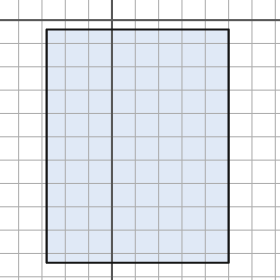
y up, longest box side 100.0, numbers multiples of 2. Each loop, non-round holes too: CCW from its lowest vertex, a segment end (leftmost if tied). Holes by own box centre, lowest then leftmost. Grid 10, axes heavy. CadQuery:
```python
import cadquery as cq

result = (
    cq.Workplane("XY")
    .moveTo(-28.0, -104.0)
    .lineTo(50.0, -104.0)
    .lineTo(50.0, -4.0)
    .lineTo(-28.0, -4.0)
    .close()
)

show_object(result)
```